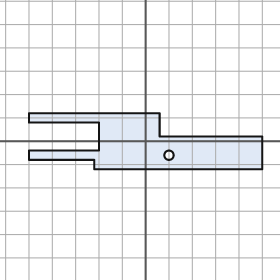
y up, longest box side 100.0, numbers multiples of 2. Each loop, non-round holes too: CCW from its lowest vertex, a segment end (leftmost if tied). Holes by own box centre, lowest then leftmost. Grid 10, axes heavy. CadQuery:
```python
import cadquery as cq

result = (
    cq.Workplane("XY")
    .moveTo(-22.0, -12.0)
    .lineTo(50.0, -12.0)
    .lineTo(50.0, 2.0)
    .lineTo(6.0, 2.0)
    .lineTo(6.0, 12.0)
    .lineTo(-50.0, 12.0)
    .lineTo(-50.0, 8.0)
    .lineTo(-20.0, 8.0)
    .lineTo(-20.0, -4.0)
    .lineTo(-50.0, -4.0)
    .lineTo(-50.0, -8.0)
    .lineTo(-22.0, -8.0)
    .close()
    .moveTo(10.0, -6.0)
    .circle(2.0)
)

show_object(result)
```